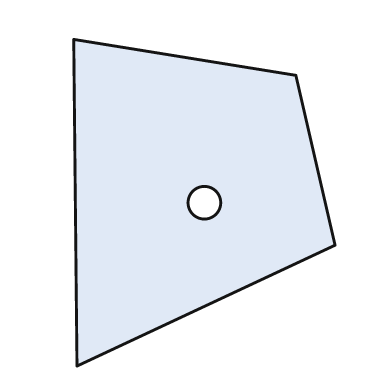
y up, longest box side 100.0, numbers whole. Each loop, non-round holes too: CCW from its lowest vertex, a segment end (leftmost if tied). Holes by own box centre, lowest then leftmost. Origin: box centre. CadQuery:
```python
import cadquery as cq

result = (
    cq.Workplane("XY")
    .moveTo(-39.0, -50.0)
    .lineTo(40.0, -13.0)
    .lineTo(28.0, 39.0)
    .lineTo(-40.0, 50.0)
    .close()
    .moveTo(0.0, 0.0)
    .circle(5.0)
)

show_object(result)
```